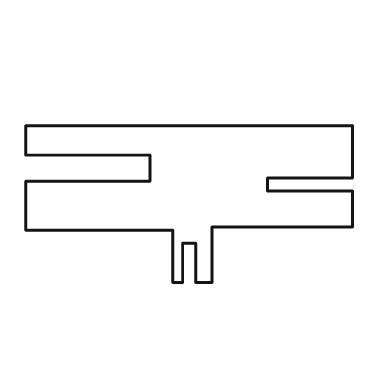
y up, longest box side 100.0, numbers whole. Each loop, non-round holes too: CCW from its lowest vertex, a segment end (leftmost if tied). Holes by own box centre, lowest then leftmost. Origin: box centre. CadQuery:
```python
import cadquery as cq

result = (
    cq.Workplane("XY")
    .moveTo(-5.0, -24.0)
    .lineTo(-2.0, -24.0)
    .lineTo(-2.0, -12.0)
    .lineTo(2.0, -12.0)
    .lineTo(2.0, -24.0)
    .lineTo(7.0, -24.0)
    .lineTo(7.0, -7.0)
    .lineTo(50.0, -7.0)
    .lineTo(50.0, 4.0)
    .lineTo(24.0, 4.0)
    .lineTo(24.0, 8.0)
    .lineTo(50.0, 8.0)
    .lineTo(50.0, 24.0)
    .lineTo(-50.0, 24.0)
    .lineTo(-50.0, 15.0)
    .lineTo(-12.0, 15.0)
    .lineTo(-12.0, 7.0)
    .lineTo(-50.0, 7.0)
    .lineTo(-50.0, -8.0)
    .lineTo(-5.0, -8.0)
    .close()
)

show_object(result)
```